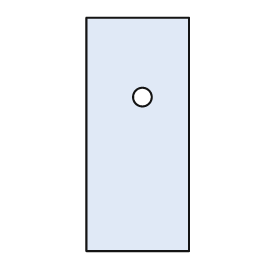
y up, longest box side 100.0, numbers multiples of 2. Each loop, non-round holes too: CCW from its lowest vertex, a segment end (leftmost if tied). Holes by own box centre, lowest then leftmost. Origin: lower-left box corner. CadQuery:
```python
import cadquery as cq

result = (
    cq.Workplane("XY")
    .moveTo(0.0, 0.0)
    .lineTo(44.0, 0.0)
    .lineTo(44.0, 100.0)
    .lineTo(0.0, 100.0)
    .close()
    .moveTo(24.0, 66.0)
    .circle(4.0)
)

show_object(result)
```